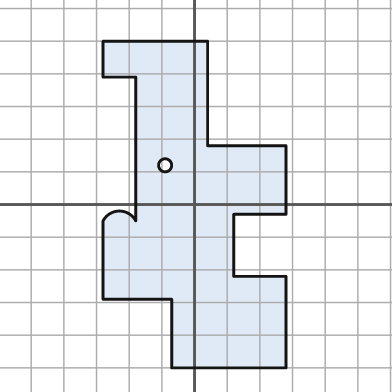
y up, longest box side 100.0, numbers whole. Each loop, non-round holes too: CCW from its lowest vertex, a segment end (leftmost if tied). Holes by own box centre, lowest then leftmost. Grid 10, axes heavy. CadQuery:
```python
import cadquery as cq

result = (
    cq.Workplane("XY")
    .moveTo(-7.0, -50.0)
    .lineTo(28.0, -50.0)
    .lineTo(28.0, -22.0)
    .lineTo(12.0, -22.0)
    .lineTo(12.0, -3.0)
    .lineTo(28.0, -3.0)
    .lineTo(28.0, 18.0)
    .lineTo(4.0, 18.0)
    .lineTo(4.0, 50.0)
    .lineTo(-28.0, 50.0)
    .lineTo(-28.0, 39.0)
    .lineTo(-18.0, 39.0)
    .lineTo(-18.0, -5.0)
    .threePointArc((-23.0, -2.0), (-28.0, -5.0))
    .lineTo(-28.0, -29.0)
    .lineTo(-7.0, -29.0)
    .close()
    .moveTo(-9.0, 12.0)
    .circle(2.0)
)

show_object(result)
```